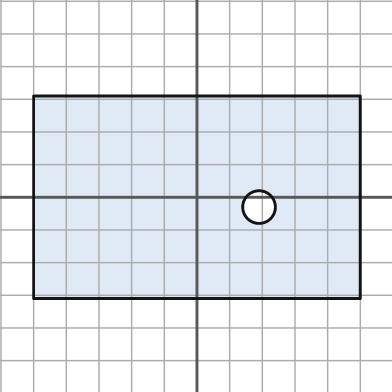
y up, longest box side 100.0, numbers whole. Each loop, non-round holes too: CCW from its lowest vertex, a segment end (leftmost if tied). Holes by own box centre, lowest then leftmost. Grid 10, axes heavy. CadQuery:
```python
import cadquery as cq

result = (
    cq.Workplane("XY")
    .moveTo(-50.0, -31.0)
    .lineTo(50.0, -31.0)
    .lineTo(50.0, 31.0)
    .lineTo(-50.0, 31.0)
    .close()
    .moveTo(19.0, -3.0)
    .circle(5.0)
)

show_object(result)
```